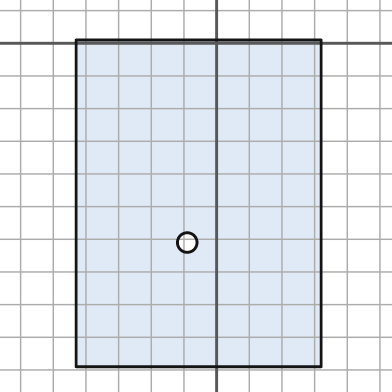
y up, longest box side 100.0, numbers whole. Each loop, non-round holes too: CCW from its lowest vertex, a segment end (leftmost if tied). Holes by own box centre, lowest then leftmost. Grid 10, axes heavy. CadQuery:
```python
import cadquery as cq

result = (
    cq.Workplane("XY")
    .moveTo(-43.0, -99.0)
    .lineTo(32.0, -99.0)
    .lineTo(32.0, 1.0)
    .lineTo(-43.0, 1.0)
    .close()
    .moveTo(-9.0, -61.0)
    .circle(3.0)
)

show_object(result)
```